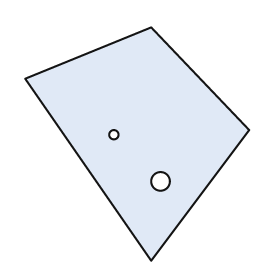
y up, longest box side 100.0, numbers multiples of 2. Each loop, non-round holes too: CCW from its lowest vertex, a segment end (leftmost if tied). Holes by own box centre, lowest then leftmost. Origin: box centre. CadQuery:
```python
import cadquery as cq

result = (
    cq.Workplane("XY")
    .moveTo(6.0, -50.0)
    .lineTo(48.0, 6.0)
    .lineTo(6.0, 50.0)
    .lineTo(-48.0, 28.0)
    .close()
    .moveTo(10.0, -16.0)
    .circle(4.0)
    .moveTo(-10.0, 4.0)
    .circle(2.0)
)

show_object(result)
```